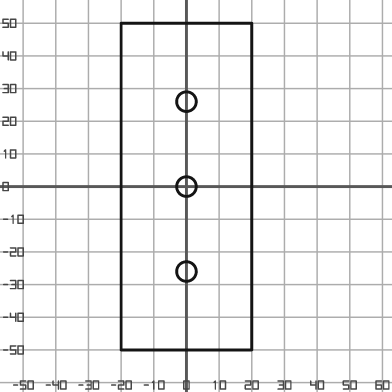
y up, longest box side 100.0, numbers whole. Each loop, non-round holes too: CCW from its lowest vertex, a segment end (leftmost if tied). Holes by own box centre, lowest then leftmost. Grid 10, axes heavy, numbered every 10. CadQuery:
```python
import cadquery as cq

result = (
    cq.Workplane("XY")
    .moveTo(-20.0, -50.0)
    .lineTo(20.0, -50.0)
    .lineTo(20.0, 50.0)
    .lineTo(-20.0, 50.0)
    .close()
    .moveTo(0.0, -26.0)
    .circle(3.0)
    .moveTo(0.0, 0.0)
    .circle(3.0)
    .moveTo(0.0, 26.0)
    .circle(3.0)
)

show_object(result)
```